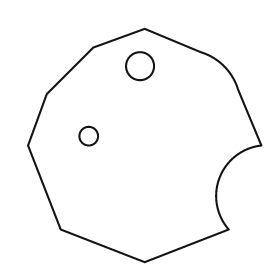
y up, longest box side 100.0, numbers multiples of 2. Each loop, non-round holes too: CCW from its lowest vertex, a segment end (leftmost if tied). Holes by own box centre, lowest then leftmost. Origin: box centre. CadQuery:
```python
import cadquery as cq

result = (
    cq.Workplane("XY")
    .moveTo(0.0, -50.0)
    .lineTo(36.0, -36.0)
    .threePointArc((32.0, -14.0), (50.0, 0.0))
    .lineTo(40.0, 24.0)
    .threePointArc((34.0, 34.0), (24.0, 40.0))
    .lineTo(0.0, 50.0)
    .lineTo(-22.0, 42.0)
    .lineTo(-42.0, 22.0)
    .lineTo(-50.0, 0.0)
    .lineTo(-36.0, -36.0)
    .close()
    .moveTo(-24.0, 4.0)
    .circle(4.0)
    .moveTo(-2.0, 34.0)
    .circle(6.0)
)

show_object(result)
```